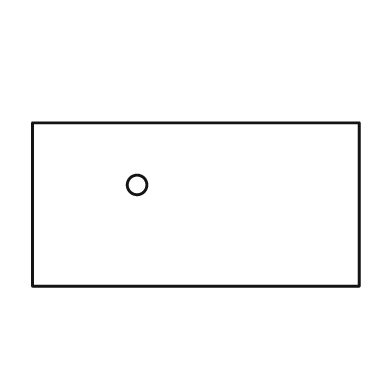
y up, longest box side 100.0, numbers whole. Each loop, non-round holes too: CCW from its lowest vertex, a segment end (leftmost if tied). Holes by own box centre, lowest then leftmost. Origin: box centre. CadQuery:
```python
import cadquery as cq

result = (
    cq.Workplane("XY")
    .moveTo(-50.0, -25.0)
    .lineTo(50.0, -25.0)
    .lineTo(50.0, 25.0)
    .lineTo(-50.0, 25.0)
    .close()
    .moveTo(-18.0, 6.0)
    .circle(3.0)
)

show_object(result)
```